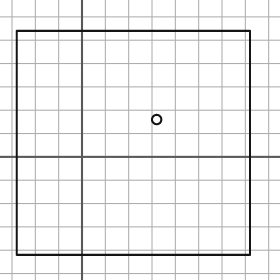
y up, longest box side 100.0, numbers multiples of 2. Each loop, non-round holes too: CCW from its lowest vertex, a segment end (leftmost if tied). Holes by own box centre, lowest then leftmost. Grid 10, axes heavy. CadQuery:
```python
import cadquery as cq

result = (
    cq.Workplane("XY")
    .moveTo(-28.0, -42.0)
    .lineTo(72.0, -42.0)
    .lineTo(72.0, 54.0)
    .lineTo(-28.0, 54.0)
    .close()
    .moveTo(32.0, 16.0)
    .circle(2.0)
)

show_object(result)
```